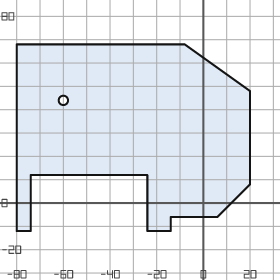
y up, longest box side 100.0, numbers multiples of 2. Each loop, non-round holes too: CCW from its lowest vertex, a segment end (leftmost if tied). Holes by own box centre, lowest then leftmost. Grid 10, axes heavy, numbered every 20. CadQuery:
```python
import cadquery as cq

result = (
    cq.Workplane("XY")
    .moveTo(-80.0, -12.0)
    .lineTo(-74.0, -12.0)
    .lineTo(-74.0, 12.0)
    .lineTo(-24.0, 12.0)
    .lineTo(-24.0, -12.0)
    .lineTo(-14.0, -12.0)
    .lineTo(-14.0, -6.0)
    .lineTo(6.0, -6.0)
    .lineTo(20.0, 8.0)
    .lineTo(20.0, 48.0)
    .lineTo(-8.0, 68.0)
    .lineTo(-80.0, 68.0)
    .close()
    .moveTo(-60.0, 44.0)
    .circle(2.0)
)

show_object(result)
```